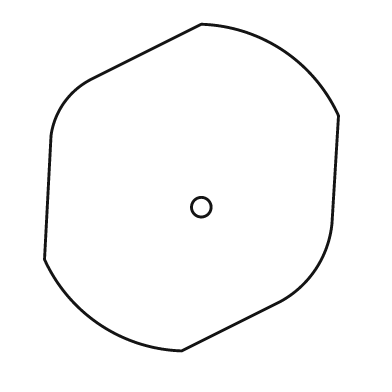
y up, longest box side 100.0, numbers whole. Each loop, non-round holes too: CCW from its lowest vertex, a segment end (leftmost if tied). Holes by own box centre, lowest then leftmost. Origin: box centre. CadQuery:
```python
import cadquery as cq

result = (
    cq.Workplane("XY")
    .moveTo(-3.0, -50.0)
    .lineTo(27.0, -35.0)
    .threePointArc((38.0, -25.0), (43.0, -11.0))
    .lineTo(45.0, 22.0)
    .threePointArc((28.0, 42.0), (3.0, 50.0))
    .lineTo(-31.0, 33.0)
    .threePointArc((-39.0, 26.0), (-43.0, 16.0))
    .lineTo(-45.0, -22.0)
    .threePointArc((-28.0, -42.0), (-3.0, -50.0))
    .close()
    .moveTo(3.0, -6.0)
    .circle(3.0)
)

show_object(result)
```